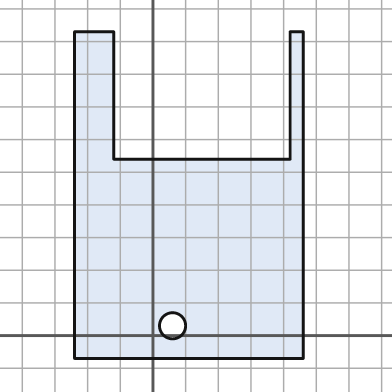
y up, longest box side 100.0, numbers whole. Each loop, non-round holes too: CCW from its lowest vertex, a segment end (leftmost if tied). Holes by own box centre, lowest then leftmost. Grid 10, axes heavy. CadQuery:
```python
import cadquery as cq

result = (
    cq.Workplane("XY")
    .moveTo(-24.0, -7.0)
    .lineTo(46.0, -7.0)
    .lineTo(46.0, 93.0)
    .lineTo(42.0, 93.0)
    .lineTo(42.0, 54.0)
    .lineTo(-12.0, 54.0)
    .lineTo(-12.0, 93.0)
    .lineTo(-24.0, 93.0)
    .close()
    .moveTo(6.0, 3.0)
    .circle(4.0)
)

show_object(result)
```